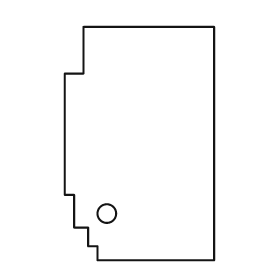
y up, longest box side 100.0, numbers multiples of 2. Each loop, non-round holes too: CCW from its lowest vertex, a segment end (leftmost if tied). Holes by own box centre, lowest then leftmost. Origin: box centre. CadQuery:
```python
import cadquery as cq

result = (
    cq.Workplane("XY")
    .moveTo(-18.0, -50.0)
    .lineTo(32.0, -50.0)
    .lineTo(32.0, 50.0)
    .lineTo(-24.0, 50.0)
    .lineTo(-24.0, 30.0)
    .lineTo(-32.0, 30.0)
    .lineTo(-32.0, -22.0)
    .lineTo(-28.0, -22.0)
    .lineTo(-28.0, -36.0)
    .lineTo(-22.0, -36.0)
    .lineTo(-22.0, -44.0)
    .lineTo(-18.0, -44.0)
    .close()
    .moveTo(-14.0, -30.0)
    .circle(4.0)
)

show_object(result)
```